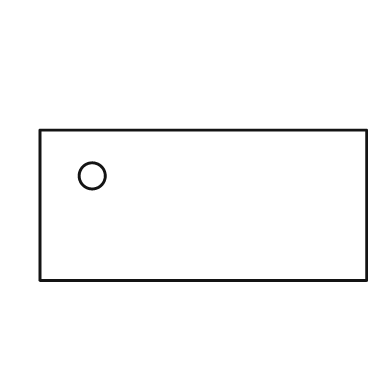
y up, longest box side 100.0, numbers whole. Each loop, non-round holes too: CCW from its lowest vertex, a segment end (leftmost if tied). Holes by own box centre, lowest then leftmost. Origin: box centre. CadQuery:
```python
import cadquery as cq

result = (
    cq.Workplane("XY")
    .moveTo(-50.0, -23.0)
    .lineTo(50.0, -23.0)
    .lineTo(50.0, 23.0)
    .lineTo(-50.0, 23.0)
    .close()
    .moveTo(-34.0, 9.0)
    .circle(4.0)
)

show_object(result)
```